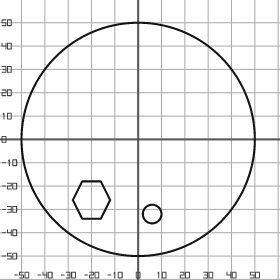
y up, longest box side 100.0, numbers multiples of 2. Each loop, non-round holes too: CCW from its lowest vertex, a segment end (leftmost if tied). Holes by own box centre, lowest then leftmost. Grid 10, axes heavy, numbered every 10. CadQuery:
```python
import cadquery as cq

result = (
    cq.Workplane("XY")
    .moveTo(0.0, 0.0)
    .circle(50.0)
    .moveTo(6.0, -32.0)
    .circle(4.0)
    .moveTo(-24.0, -34.0)
    .lineTo(-16.0, -34.0)
    .lineTo(-12.0, -26.0)
    .lineTo(-16.0, -18.0)
    .lineTo(-24.0, -18.0)
    .lineTo(-28.0, -26.0)
    .close()
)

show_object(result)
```